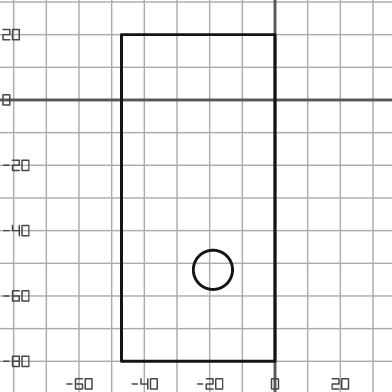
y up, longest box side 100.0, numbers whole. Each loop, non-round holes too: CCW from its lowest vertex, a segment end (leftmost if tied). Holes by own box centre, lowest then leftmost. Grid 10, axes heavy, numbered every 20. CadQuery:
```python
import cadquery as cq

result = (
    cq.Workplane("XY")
    .moveTo(-47.0, -80.0)
    .lineTo(0.0, -80.0)
    .lineTo(0.0, 20.0)
    .lineTo(-47.0, 20.0)
    .close()
    .moveTo(-19.0, -52.0)
    .circle(6.0)
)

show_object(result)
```